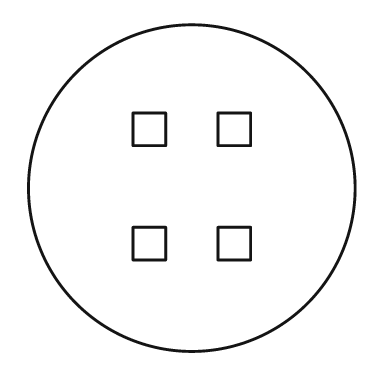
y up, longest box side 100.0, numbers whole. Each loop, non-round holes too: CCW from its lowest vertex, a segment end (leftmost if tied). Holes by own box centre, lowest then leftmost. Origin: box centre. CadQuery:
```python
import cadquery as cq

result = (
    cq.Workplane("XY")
    .moveTo(0.0, 0.0)
    .circle(50.0)
    .moveTo(-18.0, -22.0)
    .lineTo(-8.0, -22.0)
    .lineTo(-8.0, -12.0)
    .lineTo(-18.0, -12.0)
    .close()
    .moveTo(8.0, -22.0)
    .lineTo(18.0, -22.0)
    .lineTo(18.0, -12.0)
    .lineTo(8.0, -12.0)
    .close()
    .moveTo(-18.0, 13.0)
    .lineTo(-8.0, 13.0)
    .lineTo(-8.0, 23.0)
    .lineTo(-18.0, 23.0)
    .close()
    .moveTo(8.0, 13.0)
    .lineTo(18.0, 13.0)
    .lineTo(18.0, 23.0)
    .lineTo(8.0, 23.0)
    .close()
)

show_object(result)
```